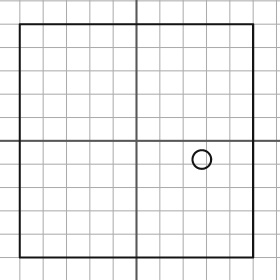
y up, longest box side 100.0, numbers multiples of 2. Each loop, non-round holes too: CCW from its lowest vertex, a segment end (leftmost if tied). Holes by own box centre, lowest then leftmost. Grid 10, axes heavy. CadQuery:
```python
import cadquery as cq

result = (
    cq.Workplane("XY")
    .moveTo(-50.0, -50.0)
    .lineTo(50.0, -50.0)
    .lineTo(50.0, 50.0)
    .lineTo(-50.0, 50.0)
    .close()
    .moveTo(28.0, -8.0)
    .circle(4.0)
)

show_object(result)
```